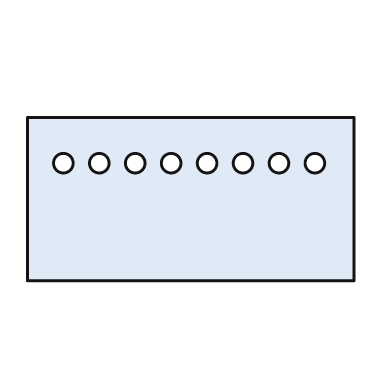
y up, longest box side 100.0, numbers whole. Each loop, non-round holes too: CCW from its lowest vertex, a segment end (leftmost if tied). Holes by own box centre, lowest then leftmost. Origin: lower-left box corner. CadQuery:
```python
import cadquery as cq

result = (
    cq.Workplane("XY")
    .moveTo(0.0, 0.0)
    .lineTo(100.0, 0.0)
    .lineTo(100.0, 50.0)
    .lineTo(0.0, 50.0)
    .close()
    .moveTo(11.0, 36.0)
    .circle(3.0)
    .moveTo(22.0, 36.0)
    .circle(3.0)
    .moveTo(33.0, 36.0)
    .circle(3.0)
    .moveTo(44.0, 36.0)
    .circle(3.0)
    .moveTo(55.0, 36.0)
    .circle(3.0)
    .moveTo(66.0, 36.0)
    .circle(3.0)
    .moveTo(77.0, 36.0)
    .circle(3.0)
    .moveTo(88.0, 36.0)
    .circle(3.0)
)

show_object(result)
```